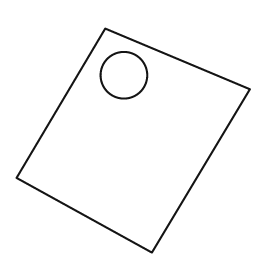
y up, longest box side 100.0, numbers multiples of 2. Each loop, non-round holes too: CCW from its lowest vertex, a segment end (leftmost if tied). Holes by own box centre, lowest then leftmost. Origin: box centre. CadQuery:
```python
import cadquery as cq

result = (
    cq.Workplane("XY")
    .moveTo(8.0, -48.0)
    .lineTo(50.0, 22.0)
    .lineTo(-12.0, 48.0)
    .lineTo(-50.0, -16.0)
    .close()
    .moveTo(-4.0, 28.0)
    .circle(10.0)
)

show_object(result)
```